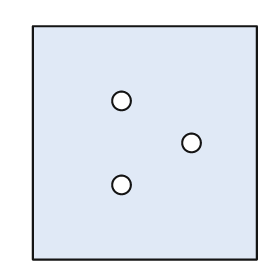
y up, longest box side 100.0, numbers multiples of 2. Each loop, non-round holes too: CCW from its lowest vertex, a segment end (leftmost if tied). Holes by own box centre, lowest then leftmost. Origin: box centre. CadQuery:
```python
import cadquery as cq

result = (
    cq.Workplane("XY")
    .moveTo(-48.0, -50.0)
    .lineTo(48.0, -50.0)
    .lineTo(48.0, 50.0)
    .lineTo(-48.0, 50.0)
    .close()
    .moveTo(-10.0, -18.0)
    .circle(4.0)
    .moveTo(20.0, 0.0)
    .circle(4.0)
    .moveTo(-10.0, 18.0)
    .circle(4.0)
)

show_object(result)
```